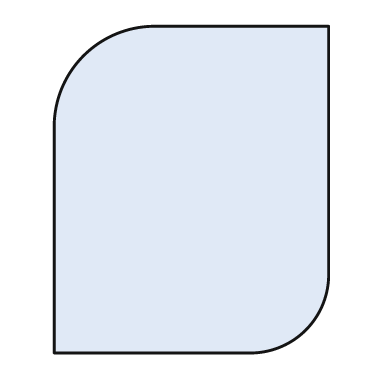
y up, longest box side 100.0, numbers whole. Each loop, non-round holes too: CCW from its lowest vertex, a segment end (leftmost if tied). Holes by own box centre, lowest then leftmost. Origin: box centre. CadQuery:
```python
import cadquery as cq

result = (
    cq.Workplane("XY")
    .moveTo(-42.0, -50.0)
    .lineTo(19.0, -50.0)
    .threePointArc((35.0, -43.0), (42.0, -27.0))
    .lineTo(42.0, 50.0)
    .lineTo(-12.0, 50.0)
    .threePointArc((-33.0, 41.0), (-42.0, 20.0))
    .close()
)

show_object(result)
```